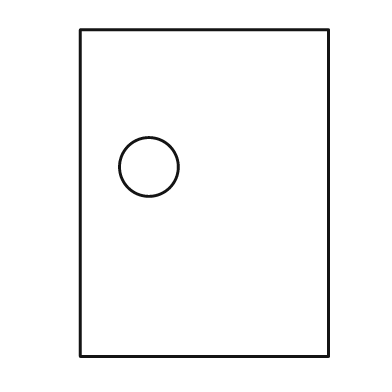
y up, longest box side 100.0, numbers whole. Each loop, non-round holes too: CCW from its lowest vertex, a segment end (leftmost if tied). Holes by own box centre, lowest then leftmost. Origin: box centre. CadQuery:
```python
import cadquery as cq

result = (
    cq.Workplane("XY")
    .moveTo(-38.0, -50.0)
    .lineTo(38.0, -50.0)
    .lineTo(38.0, 50.0)
    .lineTo(-38.0, 50.0)
    .close()
    .moveTo(-17.0, 8.0)
    .circle(9.0)
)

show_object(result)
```